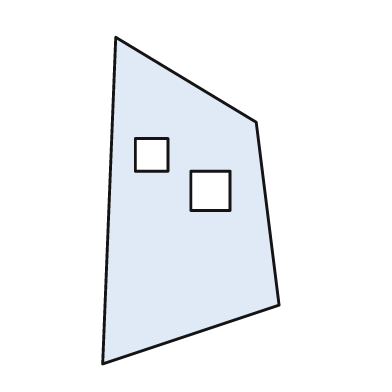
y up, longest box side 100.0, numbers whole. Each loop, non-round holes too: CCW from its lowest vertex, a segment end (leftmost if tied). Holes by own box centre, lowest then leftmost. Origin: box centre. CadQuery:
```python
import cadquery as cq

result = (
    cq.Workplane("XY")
    .moveTo(-27.0, -50.0)
    .lineTo(27.0, -32.0)
    .lineTo(20.0, 24.0)
    .lineTo(-23.0, 50.0)
    .close()
    .moveTo(0.0, -3.0)
    .lineTo(12.0, -3.0)
    .lineTo(12.0, 9.0)
    .lineTo(0.0, 9.0)
    .close()
    .moveTo(-17.0, 9.0)
    .lineTo(-7.0, 9.0)
    .lineTo(-7.0, 19.0)
    .lineTo(-17.0, 19.0)
    .close()
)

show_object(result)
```